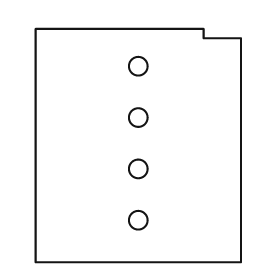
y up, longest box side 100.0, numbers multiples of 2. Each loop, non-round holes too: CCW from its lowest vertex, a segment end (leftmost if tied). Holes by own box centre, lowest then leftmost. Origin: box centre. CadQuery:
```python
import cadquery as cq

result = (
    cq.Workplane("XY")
    .moveTo(-44.0, -50.0)
    .lineTo(44.0, -50.0)
    .lineTo(44.0, 46.0)
    .lineTo(28.0, 46.0)
    .lineTo(28.0, 50.0)
    .lineTo(-44.0, 50.0)
    .close()
    .moveTo(0.0, -32.0)
    .circle(4.0)
    .moveTo(0.0, -10.0)
    .circle(4.0)
    .moveTo(0.0, 12.0)
    .circle(4.0)
    .moveTo(0.0, 34.0)
    .circle(4.0)
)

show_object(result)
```